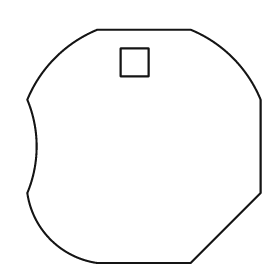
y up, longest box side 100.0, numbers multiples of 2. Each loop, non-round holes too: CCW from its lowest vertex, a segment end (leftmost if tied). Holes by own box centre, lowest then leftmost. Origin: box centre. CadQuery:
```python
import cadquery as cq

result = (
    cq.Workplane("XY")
    .moveTo(-20.0, -50.0)
    .lineTo(20.0, -50.0)
    .lineTo(50.0, -20.0)
    .lineTo(50.0, 20.0)
    .threePointArc((38.0, 38.0), (20.0, 50.0))
    .lineTo(-20.0, 50.0)
    .threePointArc((-38.0, 38.0), (-50.0, 20.0))
    .threePointArc((-46.0, 0.0), (-50.0, -20.0))
    .threePointArc((-40.0, -40.0), (-20.0, -50.0))
    .close()
    .moveTo(-10.0, 30.0)
    .lineTo(2.0, 30.0)
    .lineTo(2.0, 42.0)
    .lineTo(-10.0, 42.0)
    .close()
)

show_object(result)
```